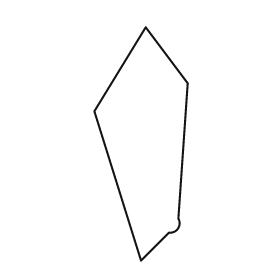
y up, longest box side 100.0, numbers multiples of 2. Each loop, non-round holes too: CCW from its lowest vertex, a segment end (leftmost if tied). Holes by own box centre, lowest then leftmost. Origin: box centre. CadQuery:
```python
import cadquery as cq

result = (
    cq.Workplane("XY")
    .moveTo(0.0, -50.0)
    .lineTo(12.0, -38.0)
    .threePointArc((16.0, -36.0), (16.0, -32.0))
    .lineTo(20.0, 26.0)
    .lineTo(2.0, 50.0)
    .lineTo(-20.0, 14.0)
    .close()
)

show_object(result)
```